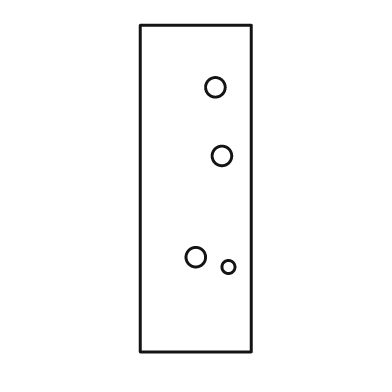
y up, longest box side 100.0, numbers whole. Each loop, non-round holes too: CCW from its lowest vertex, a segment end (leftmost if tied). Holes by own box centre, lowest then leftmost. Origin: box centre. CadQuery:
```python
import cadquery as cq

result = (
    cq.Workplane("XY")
    .moveTo(-17.0, -50.0)
    .lineTo(17.0, -50.0)
    .lineTo(17.0, 50.0)
    .lineTo(-17.0, 50.0)
    .close()
    .moveTo(10.0, -24.0)
    .circle(2.0)
    .moveTo(0.0, -21.0)
    .circle(3.0)
    .moveTo(8.0, 10.0)
    .circle(3.0)
    .moveTo(6.0, 31.0)
    .circle(3.0)
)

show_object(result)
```